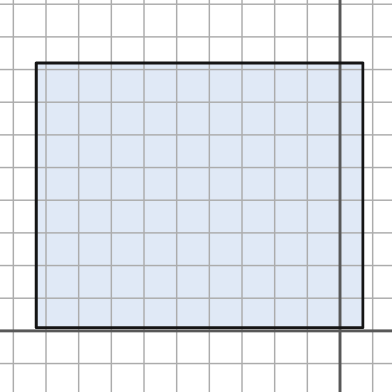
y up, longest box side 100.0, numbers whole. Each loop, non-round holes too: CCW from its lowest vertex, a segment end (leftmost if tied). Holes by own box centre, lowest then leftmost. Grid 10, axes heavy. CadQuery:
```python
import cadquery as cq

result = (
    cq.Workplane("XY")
    .moveTo(-93.0, 1.0)
    .lineTo(7.0, 1.0)
    .lineTo(7.0, 82.0)
    .lineTo(-93.0, 82.0)
    .close()
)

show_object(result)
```